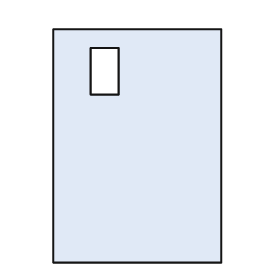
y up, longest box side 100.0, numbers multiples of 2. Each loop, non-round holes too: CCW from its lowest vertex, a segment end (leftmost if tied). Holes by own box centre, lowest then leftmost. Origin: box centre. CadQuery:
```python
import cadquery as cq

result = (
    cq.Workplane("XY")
    .moveTo(-36.0, -50.0)
    .lineTo(36.0, -50.0)
    .lineTo(36.0, 50.0)
    .lineTo(-36.0, 50.0)
    .close()
    .moveTo(-20.0, 22.0)
    .lineTo(-8.0, 22.0)
    .lineTo(-8.0, 42.0)
    .lineTo(-20.0, 42.0)
    .close()
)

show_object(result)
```